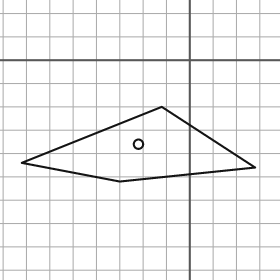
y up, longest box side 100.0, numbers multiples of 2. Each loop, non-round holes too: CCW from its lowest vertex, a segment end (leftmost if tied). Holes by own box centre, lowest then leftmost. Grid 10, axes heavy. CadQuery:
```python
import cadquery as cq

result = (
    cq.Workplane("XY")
    .moveTo(-30.0, -52.0)
    .lineTo(28.0, -46.0)
    .lineTo(-12.0, -20.0)
    .lineTo(-72.0, -44.0)
    .close()
    .moveTo(-22.0, -36.0)
    .circle(2.0)
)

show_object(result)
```